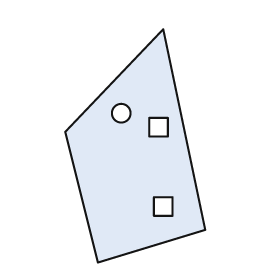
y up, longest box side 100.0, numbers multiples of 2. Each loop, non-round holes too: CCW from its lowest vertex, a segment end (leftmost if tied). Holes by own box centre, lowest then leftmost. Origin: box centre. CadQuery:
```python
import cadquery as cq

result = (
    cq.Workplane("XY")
    .moveTo(-16.0, -50.0)
    .lineTo(30.0, -36.0)
    .lineTo(12.0, 50.0)
    .lineTo(-30.0, 6.0)
    .close()
    .moveTo(8.0, -30.0)
    .lineTo(16.0, -30.0)
    .lineTo(16.0, -22.0)
    .lineTo(8.0, -22.0)
    .close()
    .moveTo(6.0, 4.0)
    .lineTo(14.0, 4.0)
    .lineTo(14.0, 12.0)
    .lineTo(6.0, 12.0)
    .close()
    .moveTo(-6.0, 14.0)
    .circle(4.0)
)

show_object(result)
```